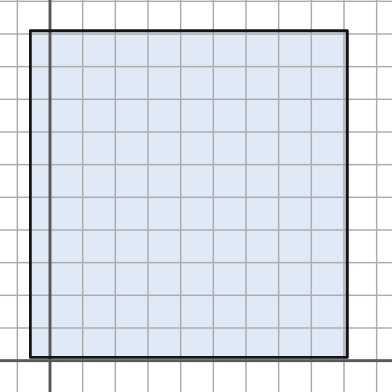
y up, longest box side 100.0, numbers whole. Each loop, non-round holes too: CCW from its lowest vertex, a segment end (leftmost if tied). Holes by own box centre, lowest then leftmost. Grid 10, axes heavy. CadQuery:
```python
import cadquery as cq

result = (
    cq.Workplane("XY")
    .moveTo(-6.0, 1.0)
    .lineTo(91.0, 1.0)
    .lineTo(91.0, 101.0)
    .lineTo(-6.0, 101.0)
    .close()
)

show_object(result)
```